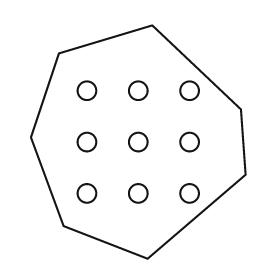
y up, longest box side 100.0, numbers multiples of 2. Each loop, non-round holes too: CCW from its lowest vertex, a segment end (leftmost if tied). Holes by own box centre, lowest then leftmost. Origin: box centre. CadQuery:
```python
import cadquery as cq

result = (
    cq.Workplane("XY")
    .moveTo(4.0, -50.0)
    .lineTo(46.0, -14.0)
    .lineTo(44.0, 14.0)
    .lineTo(6.0, 50.0)
    .lineTo(-34.0, 38.0)
    .lineTo(-46.0, 2.0)
    .lineTo(-32.0, -36.0)
    .close()
    .moveTo(-22.0, -22.0)
    .circle(4.0)
    .moveTo(0.0, -22.0)
    .circle(4.0)
    .moveTo(22.0, -22.0)
    .circle(4.0)
    .moveTo(-22.0, 0.0)
    .circle(4.0)
    .moveTo(0.0, 0.0)
    .circle(4.0)
    .moveTo(22.0, 0.0)
    .circle(4.0)
    .moveTo(-22.0, 22.0)
    .circle(4.0)
    .moveTo(0.0, 22.0)
    .circle(4.0)
    .moveTo(22.0, 22.0)
    .circle(4.0)
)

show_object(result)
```